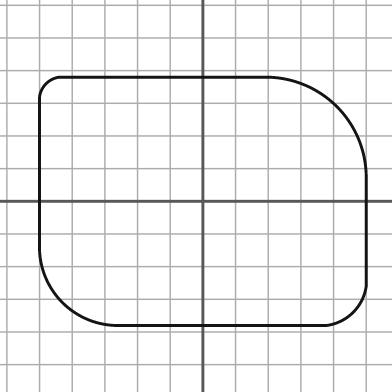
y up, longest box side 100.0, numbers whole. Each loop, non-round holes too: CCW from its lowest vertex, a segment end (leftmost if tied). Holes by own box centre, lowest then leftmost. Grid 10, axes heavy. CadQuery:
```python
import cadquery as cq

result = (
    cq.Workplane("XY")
    .moveTo(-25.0, -38.0)
    .lineTo(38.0, -38.0)
    .threePointArc((46.0, -34.0), (50.0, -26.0))
    .lineTo(50.0, 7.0)
    .threePointArc((41.0, 29.0), (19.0, 38.0))
    .lineTo(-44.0, 38.0)
    .threePointArc((-48.0, 36.0), (-50.0, 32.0))
    .lineTo(-50.0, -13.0)
    .threePointArc((-43.0, -31.0), (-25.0, -38.0))
    .close()
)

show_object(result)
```